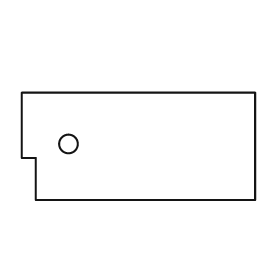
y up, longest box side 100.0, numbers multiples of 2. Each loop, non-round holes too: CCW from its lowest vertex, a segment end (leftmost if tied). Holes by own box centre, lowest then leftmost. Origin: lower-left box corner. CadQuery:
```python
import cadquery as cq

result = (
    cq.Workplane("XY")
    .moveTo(6.0, 0.0)
    .lineTo(100.0, 0.0)
    .lineTo(100.0, 46.0)
    .lineTo(0.0, 46.0)
    .lineTo(0.0, 18.0)
    .lineTo(6.0, 18.0)
    .close()
    .moveTo(20.0, 24.0)
    .circle(4.0)
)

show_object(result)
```